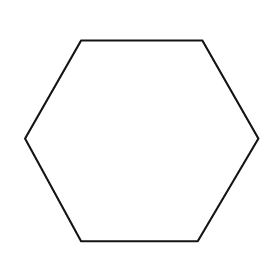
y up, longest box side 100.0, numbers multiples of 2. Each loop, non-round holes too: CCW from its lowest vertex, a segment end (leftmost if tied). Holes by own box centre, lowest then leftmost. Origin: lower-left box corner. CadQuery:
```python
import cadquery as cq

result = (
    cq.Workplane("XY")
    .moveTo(24.0, 0.0)
    .lineTo(74.0, 0.0)
    .lineTo(100.0, 44.0)
    .lineTo(76.0, 86.0)
    .lineTo(24.0, 86.0)
    .lineTo(0.0, 44.0)
    .close()
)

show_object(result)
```